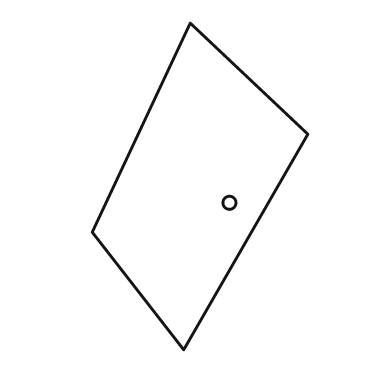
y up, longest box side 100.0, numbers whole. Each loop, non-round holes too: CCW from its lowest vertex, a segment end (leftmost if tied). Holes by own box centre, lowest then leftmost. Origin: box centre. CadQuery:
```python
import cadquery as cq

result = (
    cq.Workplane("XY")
    .moveTo(-5.0, -50.0)
    .lineTo(33.0, 16.0)
    .lineTo(-3.0, 50.0)
    .lineTo(-33.0, -14.0)
    .close()
    .moveTo(9.0, -5.0)
    .circle(2.0)
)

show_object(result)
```